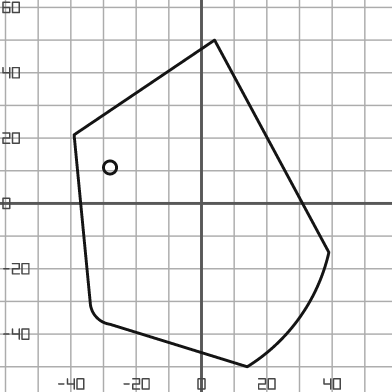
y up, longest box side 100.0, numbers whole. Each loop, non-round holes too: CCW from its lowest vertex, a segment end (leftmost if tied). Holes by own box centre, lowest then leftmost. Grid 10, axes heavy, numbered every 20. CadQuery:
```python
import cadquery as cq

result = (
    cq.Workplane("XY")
    .moveTo(14.0, -50.0)
    .threePointArc((30.0, -35.0), (39.0, -15.0))
    .lineTo(4.0, 50.0)
    .lineTo(-39.0, 21.0)
    .lineTo(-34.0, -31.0)
    .threePointArc((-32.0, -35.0), (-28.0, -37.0))
    .close()
    .moveTo(-28.0, 11.0)
    .circle(2.0)
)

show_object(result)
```